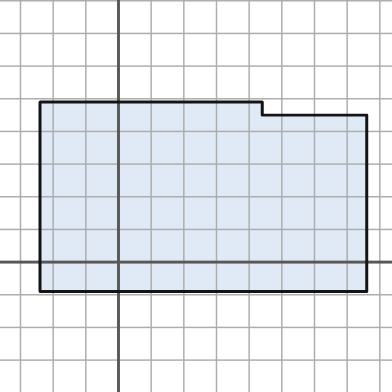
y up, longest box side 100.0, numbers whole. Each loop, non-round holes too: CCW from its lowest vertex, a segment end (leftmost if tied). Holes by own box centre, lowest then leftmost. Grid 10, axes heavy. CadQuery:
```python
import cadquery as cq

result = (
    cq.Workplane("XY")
    .moveTo(-24.0, -9.0)
    .lineTo(76.0, -9.0)
    .lineTo(76.0, 45.0)
    .lineTo(44.0, 45.0)
    .lineTo(44.0, 49.0)
    .lineTo(-24.0, 49.0)
    .close()
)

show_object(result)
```